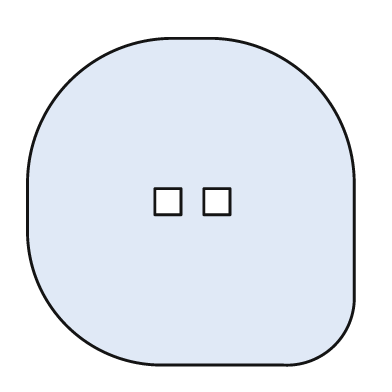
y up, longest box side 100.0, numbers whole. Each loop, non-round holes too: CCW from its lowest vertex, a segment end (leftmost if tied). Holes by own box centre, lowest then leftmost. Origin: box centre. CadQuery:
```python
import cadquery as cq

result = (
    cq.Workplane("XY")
    .moveTo(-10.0, -50.0)
    .lineTo(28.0, -50.0)
    .threePointArc((44.0, -44.0), (50.0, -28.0))
    .lineTo(50.0, 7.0)
    .threePointArc((37.0, 37.0), (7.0, 50.0))
    .lineTo(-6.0, 50.0)
    .threePointArc((-37.0, 37.0), (-50.0, 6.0))
    .lineTo(-50.0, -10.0)
    .threePointArc((-38.0, -38.0), (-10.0, -50.0))
    .close()
    .moveTo(-11.0, -4.0)
    .lineTo(-3.0, -4.0)
    .lineTo(-3.0, 4.0)
    .lineTo(-11.0, 4.0)
    .close()
    .moveTo(4.0, -4.0)
    .lineTo(12.0, -4.0)
    .lineTo(12.0, 4.0)
    .lineTo(4.0, 4.0)
    .close()
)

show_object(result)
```